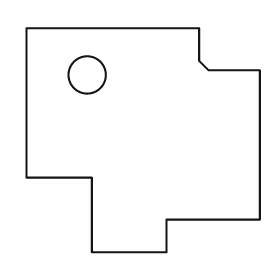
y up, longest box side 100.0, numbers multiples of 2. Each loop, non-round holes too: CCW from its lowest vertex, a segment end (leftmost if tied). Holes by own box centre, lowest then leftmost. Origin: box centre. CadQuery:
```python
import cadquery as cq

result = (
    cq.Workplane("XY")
    .moveTo(-22.0, -48.0)
    .lineTo(10.0, -48.0)
    .lineTo(10.0, -34.0)
    .lineTo(50.0, -34.0)
    .lineTo(50.0, 30.0)
    .lineTo(28.0, 30.0)
    .lineTo(24.0, 34.0)
    .lineTo(24.0, 48.0)
    .lineTo(-50.0, 48.0)
    .lineTo(-50.0, -16.0)
    .lineTo(-22.0, -16.0)
    .close()
    .moveTo(-24.0, 28.0)
    .circle(8.0)
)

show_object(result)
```